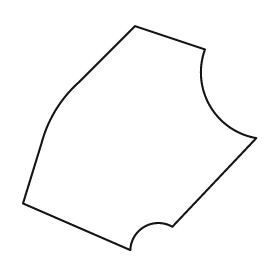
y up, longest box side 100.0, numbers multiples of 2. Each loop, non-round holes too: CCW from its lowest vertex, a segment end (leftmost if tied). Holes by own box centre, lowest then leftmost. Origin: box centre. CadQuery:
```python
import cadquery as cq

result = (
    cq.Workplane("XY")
    .moveTo(-4.0, -48.0)
    .threePointArc((2.0, -38.0), (14.0, -38.0))
    .lineTo(50.0, 0.0)
    .threePointArc((30.0, 14.0), (28.0, 38.0))
    .lineTo(-2.0, 48.0)
    .lineTo(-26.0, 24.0)
    .threePointArc((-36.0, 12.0), (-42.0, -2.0))
    .lineTo(-50.0, -28.0)
    .close()
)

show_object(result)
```